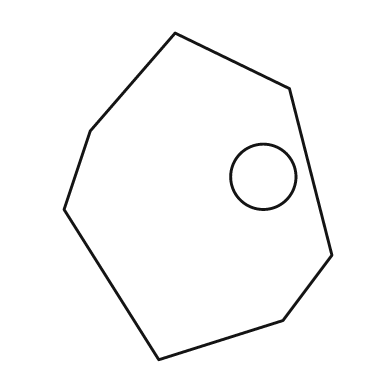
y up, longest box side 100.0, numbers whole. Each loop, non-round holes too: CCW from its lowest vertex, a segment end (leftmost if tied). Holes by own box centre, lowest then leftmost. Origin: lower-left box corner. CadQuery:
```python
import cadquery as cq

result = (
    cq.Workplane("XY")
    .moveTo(29.0, 0.0)
    .lineTo(67.0, 12.0)
    .lineTo(82.0, 32.0)
    .lineTo(69.0, 83.0)
    .lineTo(34.0, 100.0)
    .lineTo(8.0, 70.0)
    .lineTo(0.0, 46.0)
    .close()
    .moveTo(61.0, 56.0)
    .circle(10.0)
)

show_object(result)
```